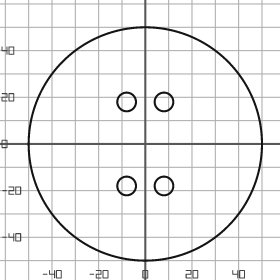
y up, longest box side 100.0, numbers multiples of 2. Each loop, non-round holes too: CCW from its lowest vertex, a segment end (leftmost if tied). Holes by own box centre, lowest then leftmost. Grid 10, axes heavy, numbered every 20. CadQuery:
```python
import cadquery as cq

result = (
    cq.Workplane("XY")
    .moveTo(0.0, 0.0)
    .circle(50.0)
    .moveTo(-8.0, -18.0)
    .circle(4.0)
    .moveTo(8.0, -18.0)
    .circle(4.0)
    .moveTo(-8.0, 18.0)
    .circle(4.0)
    .moveTo(8.0, 18.0)
    .circle(4.0)
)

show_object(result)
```